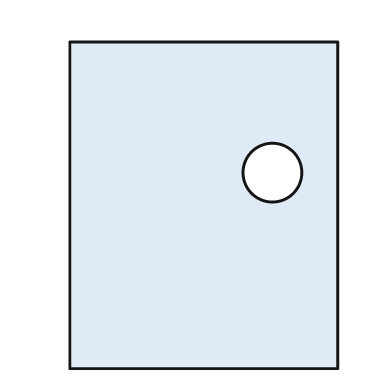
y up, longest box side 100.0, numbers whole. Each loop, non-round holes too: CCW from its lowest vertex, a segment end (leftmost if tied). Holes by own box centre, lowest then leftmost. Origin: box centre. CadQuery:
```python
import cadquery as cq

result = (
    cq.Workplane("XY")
    .moveTo(-41.0, -50.0)
    .lineTo(41.0, -50.0)
    .lineTo(41.0, 50.0)
    .lineTo(-41.0, 50.0)
    .close()
    .moveTo(21.0, 10.0)
    .circle(9.0)
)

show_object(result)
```